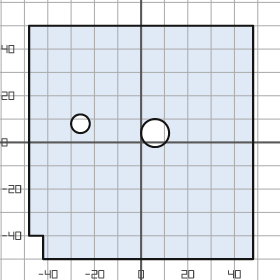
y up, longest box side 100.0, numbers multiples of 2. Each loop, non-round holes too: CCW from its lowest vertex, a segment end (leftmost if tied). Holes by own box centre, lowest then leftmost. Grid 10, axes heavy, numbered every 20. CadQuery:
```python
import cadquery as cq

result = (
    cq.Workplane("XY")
    .moveTo(-42.0, -50.0)
    .lineTo(48.0, -50.0)
    .lineTo(48.0, 50.0)
    .lineTo(-48.0, 50.0)
    .lineTo(-48.0, -40.0)
    .lineTo(-42.0, -40.0)
    .close()
    .moveTo(6.0, 4.0)
    .circle(6.0)
    .moveTo(-26.0, 8.0)
    .circle(4.0)
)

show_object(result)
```